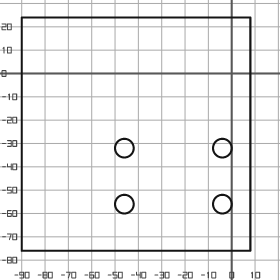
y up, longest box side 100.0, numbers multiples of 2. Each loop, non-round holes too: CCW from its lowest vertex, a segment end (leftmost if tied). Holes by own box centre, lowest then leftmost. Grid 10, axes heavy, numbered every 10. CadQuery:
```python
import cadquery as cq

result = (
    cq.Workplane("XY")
    .moveTo(-90.0, -76.0)
    .lineTo(8.0, -76.0)
    .lineTo(8.0, 24.0)
    .lineTo(-90.0, 24.0)
    .close()
    .moveTo(-46.0, -56.0)
    .circle(4.0)
    .moveTo(-4.0, -56.0)
    .circle(4.0)
    .moveTo(-46.0, -32.0)
    .circle(4.0)
    .moveTo(-4.0, -32.0)
    .circle(4.0)
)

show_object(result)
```